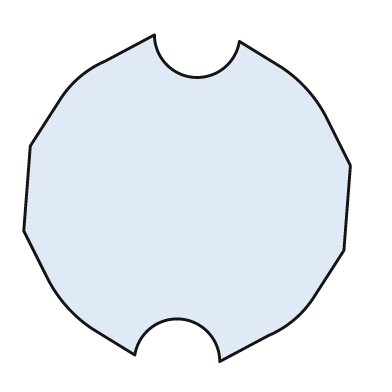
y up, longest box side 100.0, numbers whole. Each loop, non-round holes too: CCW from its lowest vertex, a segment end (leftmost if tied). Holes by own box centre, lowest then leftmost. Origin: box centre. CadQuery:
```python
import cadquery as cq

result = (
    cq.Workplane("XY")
    .moveTo(10.0, -50.0)
    .lineTo(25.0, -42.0)
    .threePointArc((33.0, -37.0), (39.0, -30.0))
    .lineTo(48.0, -16.0)
    .lineTo(50.0, 10.0)
    .lineTo(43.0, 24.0)
    .threePointArc((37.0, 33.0), (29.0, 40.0))
    .lineTo(16.0, 48.0)
    .threePointArc((2.0, 37.0), (-10.0, 50.0))
    .lineTo(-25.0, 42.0)
    .threePointArc((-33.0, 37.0), (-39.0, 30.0))
    .lineTo(-48.0, 16.0)
    .lineTo(-50.0, -10.0)
    .lineTo(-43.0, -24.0)
    .threePointArc((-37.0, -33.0), (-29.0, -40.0))
    .lineTo(-16.0, -48.0)
    .threePointArc((-2.0, -37.0), (10.0, -50.0))
    .close()
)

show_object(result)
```